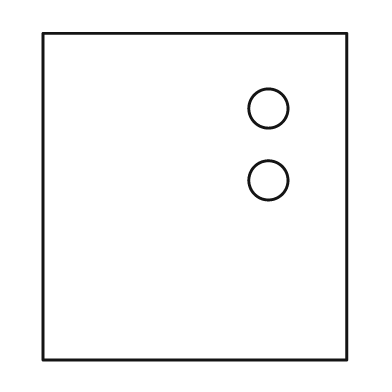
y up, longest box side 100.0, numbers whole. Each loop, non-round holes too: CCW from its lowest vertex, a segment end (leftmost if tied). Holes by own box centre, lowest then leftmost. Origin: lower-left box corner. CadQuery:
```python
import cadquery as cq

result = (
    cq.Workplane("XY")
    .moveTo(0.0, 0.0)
    .lineTo(93.0, 0.0)
    .lineTo(93.0, 100.0)
    .lineTo(0.0, 100.0)
    .close()
    .moveTo(69.0, 55.0)
    .circle(6.0)
    .moveTo(69.0, 77.0)
    .circle(6.0)
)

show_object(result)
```